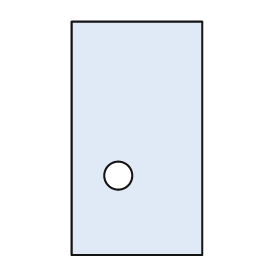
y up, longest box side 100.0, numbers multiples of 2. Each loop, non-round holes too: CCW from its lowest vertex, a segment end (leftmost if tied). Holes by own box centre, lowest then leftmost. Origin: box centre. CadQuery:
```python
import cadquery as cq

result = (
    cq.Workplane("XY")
    .moveTo(-28.0, -50.0)
    .lineTo(28.0, -50.0)
    .lineTo(28.0, 50.0)
    .lineTo(-28.0, 50.0)
    .close()
    .moveTo(-8.0, -16.0)
    .circle(6.0)
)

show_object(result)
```